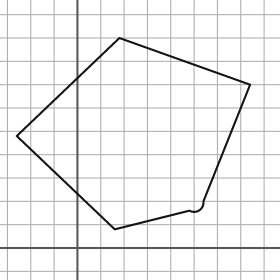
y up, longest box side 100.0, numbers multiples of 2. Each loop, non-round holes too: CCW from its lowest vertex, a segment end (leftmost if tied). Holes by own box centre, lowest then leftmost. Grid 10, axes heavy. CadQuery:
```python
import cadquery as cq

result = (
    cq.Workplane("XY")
    .moveTo(16.0, 8.0)
    .lineTo(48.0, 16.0)
    .threePointArc((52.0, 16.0), (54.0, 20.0))
    .lineTo(74.0, 70.0)
    .lineTo(18.0, 90.0)
    .lineTo(-26.0, 48.0)
    .close()
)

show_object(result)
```